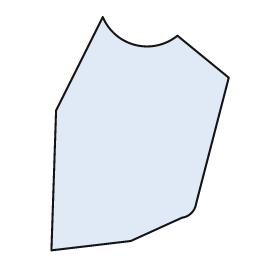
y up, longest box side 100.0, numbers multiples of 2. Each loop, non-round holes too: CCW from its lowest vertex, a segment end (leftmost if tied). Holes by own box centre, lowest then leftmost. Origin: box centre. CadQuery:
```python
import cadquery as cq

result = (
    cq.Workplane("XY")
    .moveTo(-38.0, -50.0)
    .lineTo(-4.0, -46.0)
    .lineTo(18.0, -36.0)
    .threePointArc((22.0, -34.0), (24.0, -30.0))
    .lineTo(38.0, 24.0)
    .lineTo(16.0, 42.0)
    .threePointArc((-2.0, 38.0), (-16.0, 50.0))
    .lineTo(-36.0, 10.0)
    .close()
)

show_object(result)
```